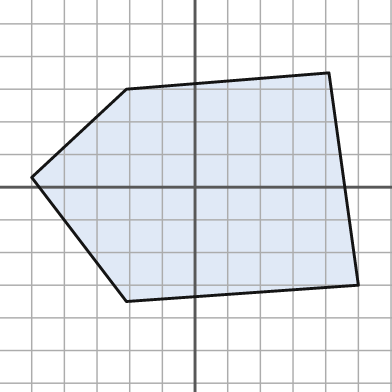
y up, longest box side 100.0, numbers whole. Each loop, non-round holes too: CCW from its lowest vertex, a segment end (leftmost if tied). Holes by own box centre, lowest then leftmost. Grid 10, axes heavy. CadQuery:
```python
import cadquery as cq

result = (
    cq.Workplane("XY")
    .moveTo(-21.0, -35.0)
    .lineTo(50.0, -30.0)
    .lineTo(41.0, 35.0)
    .lineTo(-21.0, 30.0)
    .lineTo(-50.0, 3.0)
    .close()
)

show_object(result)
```